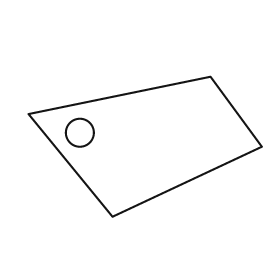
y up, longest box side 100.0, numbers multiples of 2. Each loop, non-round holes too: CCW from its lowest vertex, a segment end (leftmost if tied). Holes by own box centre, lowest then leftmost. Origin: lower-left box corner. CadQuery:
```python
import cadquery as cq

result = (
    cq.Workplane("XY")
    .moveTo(36.0, 0.0)
    .lineTo(100.0, 30.0)
    .lineTo(78.0, 60.0)
    .lineTo(0.0, 44.0)
    .close()
    .moveTo(22.0, 36.0)
    .circle(6.0)
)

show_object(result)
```